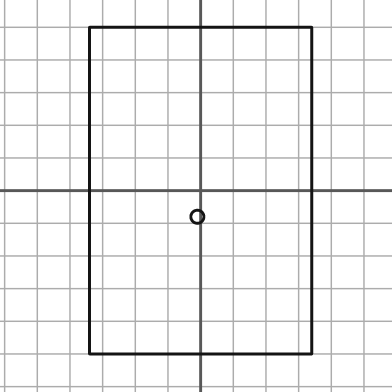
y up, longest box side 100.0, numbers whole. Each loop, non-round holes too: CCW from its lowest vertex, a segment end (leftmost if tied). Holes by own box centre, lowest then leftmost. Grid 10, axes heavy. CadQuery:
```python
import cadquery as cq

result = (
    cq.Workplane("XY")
    .moveTo(-34.0, -50.0)
    .lineTo(34.0, -50.0)
    .lineTo(34.0, 50.0)
    .lineTo(-34.0, 50.0)
    .close()
    .moveTo(-1.0, -8.0)
    .circle(2.0)
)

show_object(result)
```